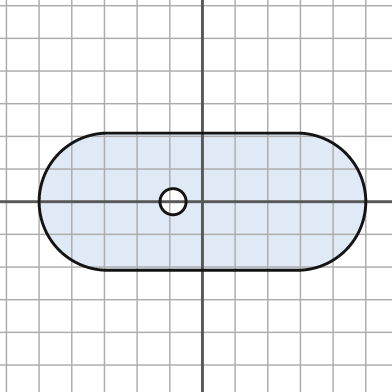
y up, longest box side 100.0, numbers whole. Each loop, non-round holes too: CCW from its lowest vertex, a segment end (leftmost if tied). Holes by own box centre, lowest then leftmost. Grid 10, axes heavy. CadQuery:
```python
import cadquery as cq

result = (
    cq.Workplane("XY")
    .moveTo(-29.0, -21.0)
    .lineTo(29.0, -21.0)
    .threePointArc((50.0, 0.0), (29.0, 21.0))
    .lineTo(-29.0, 21.0)
    .threePointArc((-50.0, 0.0), (-29.0, -21.0))
    .close()
    .moveTo(-9.0, 0.0)
    .circle(4.0)
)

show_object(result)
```